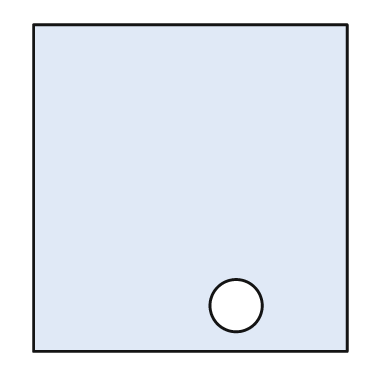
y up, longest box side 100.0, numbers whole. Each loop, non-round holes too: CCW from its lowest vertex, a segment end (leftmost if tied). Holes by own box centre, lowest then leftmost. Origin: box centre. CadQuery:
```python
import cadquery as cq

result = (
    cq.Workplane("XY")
    .moveTo(-48.0, -50.0)
    .lineTo(48.0, -50.0)
    .lineTo(48.0, 50.0)
    .lineTo(-48.0, 50.0)
    .close()
    .moveTo(14.0, -36.0)
    .circle(8.0)
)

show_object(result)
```